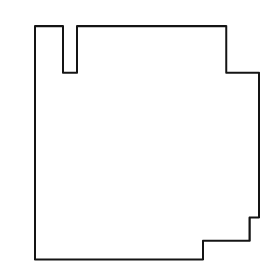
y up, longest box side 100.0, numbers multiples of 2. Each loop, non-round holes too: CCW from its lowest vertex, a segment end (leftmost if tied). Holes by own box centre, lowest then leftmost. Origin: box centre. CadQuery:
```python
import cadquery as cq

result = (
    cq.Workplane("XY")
    .moveTo(-48.0, -50.0)
    .lineTo(24.0, -50.0)
    .lineTo(24.0, -42.0)
    .lineTo(44.0, -42.0)
    .lineTo(44.0, -32.0)
    .lineTo(48.0, -32.0)
    .lineTo(48.0, 30.0)
    .lineTo(34.0, 30.0)
    .lineTo(34.0, 50.0)
    .lineTo(-30.0, 50.0)
    .lineTo(-30.0, 30.0)
    .lineTo(-36.0, 30.0)
    .lineTo(-36.0, 50.0)
    .lineTo(-48.0, 50.0)
    .close()
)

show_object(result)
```